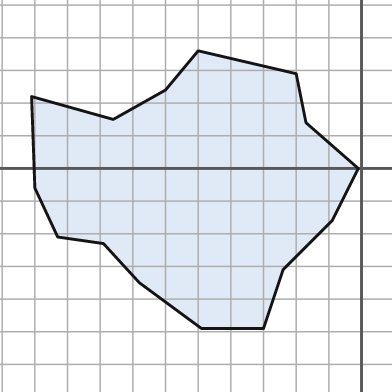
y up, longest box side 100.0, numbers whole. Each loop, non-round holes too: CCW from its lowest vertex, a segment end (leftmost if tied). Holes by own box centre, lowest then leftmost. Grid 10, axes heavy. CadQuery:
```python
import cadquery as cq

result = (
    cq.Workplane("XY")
    .moveTo(-49.0, -49.0)
    .lineTo(-30.0, -49.0)
    .lineTo(-24.0, -31.0)
    .lineTo(-9.0, -16.0)
    .lineTo(-1.0, 0.0)
    .lineTo(-17.0, 14.0)
    .lineTo(-20.0, 29.0)
    .lineTo(-50.0, 36.0)
    .lineTo(-60.0, 24.0)
    .lineTo(-76.0, 15.0)
    .lineTo(-101.0, 22.0)
    .lineTo(-100.0, -6.0)
    .lineTo(-93.0, -21.0)
    .lineTo(-79.0, -23.0)
    .lineTo(-68.0, -35.0)
    .close()
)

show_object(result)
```